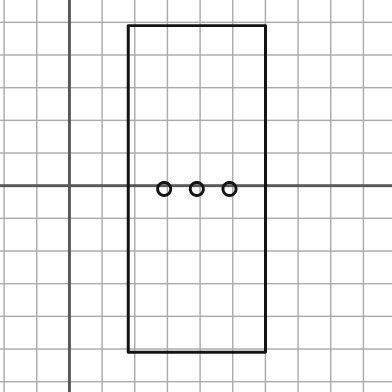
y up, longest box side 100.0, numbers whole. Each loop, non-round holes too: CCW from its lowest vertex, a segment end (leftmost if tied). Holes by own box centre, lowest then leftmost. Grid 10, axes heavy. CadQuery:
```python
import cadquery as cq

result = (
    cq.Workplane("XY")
    .moveTo(18.0, -51.0)
    .lineTo(60.0, -51.0)
    .lineTo(60.0, 49.0)
    .lineTo(18.0, 49.0)
    .close()
    .moveTo(29.0, -1.0)
    .circle(2.0)
    .moveTo(39.0, -1.0)
    .circle(2.0)
    .moveTo(49.0, -1.0)
    .circle(2.0)
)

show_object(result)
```